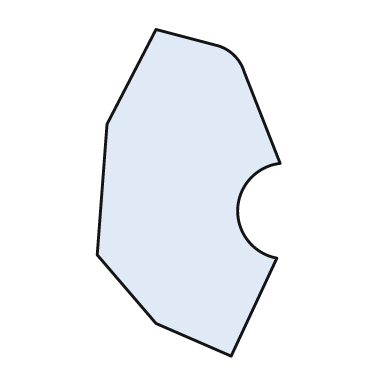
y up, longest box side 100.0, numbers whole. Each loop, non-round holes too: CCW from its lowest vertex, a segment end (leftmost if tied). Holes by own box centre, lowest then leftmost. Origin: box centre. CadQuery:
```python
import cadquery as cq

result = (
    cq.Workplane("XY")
    .moveTo(13.0, -50.0)
    .lineTo(27.0, -20.0)
    .threePointArc((15.0, -5.0), (28.0, 9.0))
    .lineTo(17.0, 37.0)
    .threePointArc((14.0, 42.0), (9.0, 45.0))
    .lineTo(-10.0, 50.0)
    .lineTo(-25.0, 21.0)
    .lineTo(-28.0, -19.0)
    .lineTo(-10.0, -40.0)
    .close()
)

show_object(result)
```